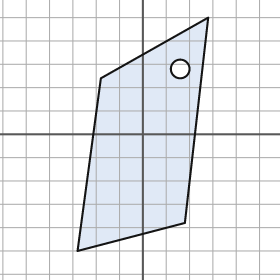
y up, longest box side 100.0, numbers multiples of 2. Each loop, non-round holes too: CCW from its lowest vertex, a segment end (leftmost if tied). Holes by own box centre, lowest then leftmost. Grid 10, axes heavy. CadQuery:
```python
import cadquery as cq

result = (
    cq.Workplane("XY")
    .moveTo(-28.0, -50.0)
    .lineTo(18.0, -38.0)
    .lineTo(28.0, 50.0)
    .lineTo(-18.0, 24.0)
    .close()
    .moveTo(16.0, 28.0)
    .circle(4.0)
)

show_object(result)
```